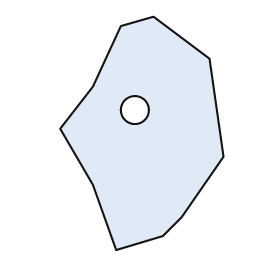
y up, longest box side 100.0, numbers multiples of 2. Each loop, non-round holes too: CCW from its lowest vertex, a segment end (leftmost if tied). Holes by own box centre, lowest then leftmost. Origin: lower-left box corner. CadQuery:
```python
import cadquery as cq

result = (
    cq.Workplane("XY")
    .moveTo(24.0, 0.0)
    .lineTo(44.0, 6.0)
    .lineTo(52.0, 14.0)
    .lineTo(70.0, 40.0)
    .lineTo(64.0, 82.0)
    .lineTo(40.0, 100.0)
    .lineTo(26.0, 96.0)
    .lineTo(14.0, 70.0)
    .lineTo(0.0, 52.0)
    .lineTo(14.0, 28.0)
    .close()
    .moveTo(32.0, 60.0)
    .circle(6.0)
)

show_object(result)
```